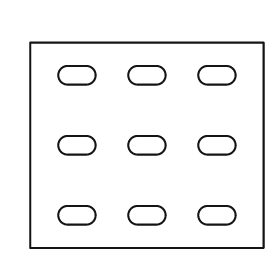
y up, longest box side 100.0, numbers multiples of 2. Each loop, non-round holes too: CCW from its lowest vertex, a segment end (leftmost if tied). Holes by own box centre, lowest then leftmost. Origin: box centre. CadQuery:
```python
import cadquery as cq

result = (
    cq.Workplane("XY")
    .moveTo(-50.0, -44.0)
    .lineTo(50.0, -44.0)
    .lineTo(50.0, 44.0)
    .lineTo(-50.0, 44.0)
    .close()
    .moveTo(-34.0, -34.0)
    .lineTo(-26.0, -34.0)
    .threePointArc((-22.0, -30.0), (-26.0, -26.0))
    .lineTo(-34.0, -26.0)
    .threePointArc((-38.0, -30.0), (-34.0, -34.0))
    .close()
    .moveTo(-4.0, -34.0)
    .lineTo(4.0, -34.0)
    .threePointArc((8.0, -30.0), (4.0, -26.0))
    .lineTo(-4.0, -26.0)
    .threePointArc((-8.0, -30.0), (-4.0, -34.0))
    .close()
    .moveTo(26.0, -34.0)
    .lineTo(34.0, -34.0)
    .threePointArc((38.0, -30.0), (34.0, -26.0))
    .lineTo(26.0, -26.0)
    .threePointArc((22.0, -30.0), (26.0, -34.0))
    .close()
    .moveTo(-34.0, -4.0)
    .lineTo(-26.0, -4.0)
    .threePointArc((-22.0, 0.0), (-26.0, 4.0))
    .lineTo(-34.0, 4.0)
    .threePointArc((-38.0, 0.0), (-34.0, -4.0))
    .close()
    .moveTo(-4.0, -4.0)
    .lineTo(4.0, -4.0)
    .threePointArc((8.0, 0.0), (4.0, 4.0))
    .lineTo(-4.0, 4.0)
    .threePointArc((-8.0, 0.0), (-4.0, -4.0))
    .close()
    .moveTo(26.0, -4.0)
    .lineTo(34.0, -4.0)
    .threePointArc((38.0, 0.0), (34.0, 4.0))
    .lineTo(26.0, 4.0)
    .threePointArc((22.0, 0.0), (26.0, -4.0))
    .close()
    .moveTo(-34.0, 26.0)
    .lineTo(-26.0, 26.0)
    .threePointArc((-22.0, 30.0), (-26.0, 34.0))
    .lineTo(-34.0, 34.0)
    .threePointArc((-38.0, 30.0), (-34.0, 26.0))
    .close()
    .moveTo(-4.0, 26.0)
    .lineTo(4.0, 26.0)
    .threePointArc((8.0, 30.0), (4.0, 34.0))
    .lineTo(-4.0, 34.0)
    .threePointArc((-8.0, 30.0), (-4.0, 26.0))
    .close()
    .moveTo(26.0, 26.0)
    .lineTo(34.0, 26.0)
    .threePointArc((38.0, 30.0), (34.0, 34.0))
    .lineTo(26.0, 34.0)
    .threePointArc((22.0, 30.0), (26.0, 26.0))
    .close()
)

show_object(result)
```